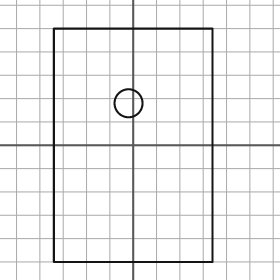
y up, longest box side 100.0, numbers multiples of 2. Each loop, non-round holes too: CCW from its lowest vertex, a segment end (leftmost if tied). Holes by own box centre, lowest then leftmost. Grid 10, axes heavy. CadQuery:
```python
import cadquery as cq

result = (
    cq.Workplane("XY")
    .moveTo(-34.0, -50.0)
    .lineTo(34.0, -50.0)
    .lineTo(34.0, 50.0)
    .lineTo(-34.0, 50.0)
    .close()
    .moveTo(-2.0, 18.0)
    .circle(6.0)
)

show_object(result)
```